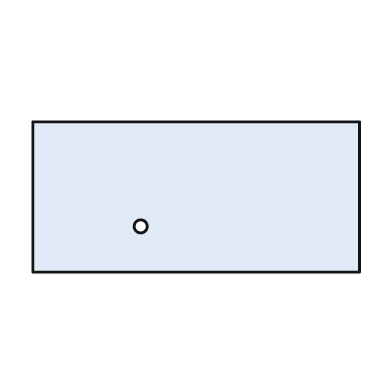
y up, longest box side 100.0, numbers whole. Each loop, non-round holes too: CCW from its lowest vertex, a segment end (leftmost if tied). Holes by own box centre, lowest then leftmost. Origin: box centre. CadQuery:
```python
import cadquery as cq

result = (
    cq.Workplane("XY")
    .moveTo(-50.0, -23.0)
    .lineTo(50.0, -23.0)
    .lineTo(50.0, 23.0)
    .lineTo(-50.0, 23.0)
    .close()
    .moveTo(-17.0, -9.0)
    .circle(2.0)
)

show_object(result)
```